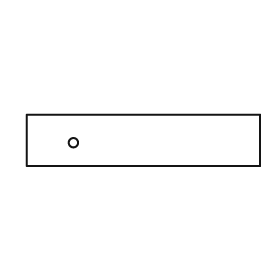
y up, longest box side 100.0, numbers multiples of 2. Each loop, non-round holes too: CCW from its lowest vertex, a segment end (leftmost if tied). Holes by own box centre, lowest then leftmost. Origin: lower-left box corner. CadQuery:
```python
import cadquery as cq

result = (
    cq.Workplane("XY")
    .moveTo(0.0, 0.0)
    .lineTo(100.0, 0.0)
    .lineTo(100.0, 22.0)
    .lineTo(0.0, 22.0)
    .close()
    .moveTo(20.0, 10.0)
    .circle(2.0)
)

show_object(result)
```